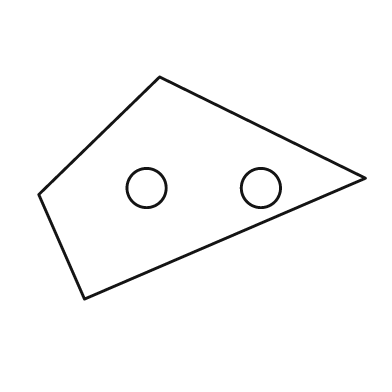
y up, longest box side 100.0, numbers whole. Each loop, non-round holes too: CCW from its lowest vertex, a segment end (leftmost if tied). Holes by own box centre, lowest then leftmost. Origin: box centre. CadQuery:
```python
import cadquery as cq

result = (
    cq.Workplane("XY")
    .moveTo(-36.0, -34.0)
    .lineTo(50.0, 3.0)
    .lineTo(-13.0, 34.0)
    .lineTo(-50.0, -2.0)
    .close()
    .moveTo(-17.0, 0.0)
    .circle(6.0)
    .moveTo(18.0, 0.0)
    .circle(6.0)
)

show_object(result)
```